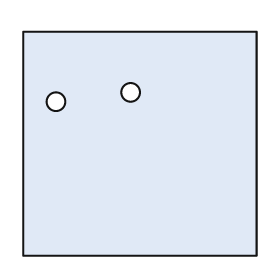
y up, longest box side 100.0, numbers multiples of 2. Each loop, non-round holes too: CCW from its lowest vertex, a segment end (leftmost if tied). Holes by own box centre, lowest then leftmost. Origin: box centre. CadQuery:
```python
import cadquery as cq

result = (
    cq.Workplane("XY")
    .moveTo(-50.0, -48.0)
    .lineTo(50.0, -48.0)
    .lineTo(50.0, 48.0)
    .lineTo(-50.0, 48.0)
    .close()
    .moveTo(-36.0, 18.0)
    .circle(4.0)
    .moveTo(-4.0, 22.0)
    .circle(4.0)
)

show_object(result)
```